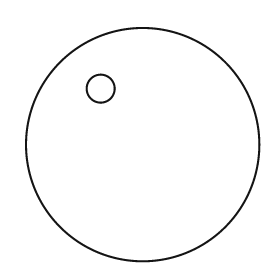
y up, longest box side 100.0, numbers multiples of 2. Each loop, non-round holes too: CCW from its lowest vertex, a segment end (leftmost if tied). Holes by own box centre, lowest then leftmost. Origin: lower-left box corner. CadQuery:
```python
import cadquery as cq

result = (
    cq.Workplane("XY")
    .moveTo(50.0, 50.0)
    .circle(50.0)
    .moveTo(32.0, 74.0)
    .circle(6.0)
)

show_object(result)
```